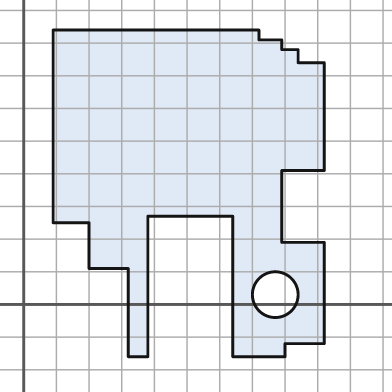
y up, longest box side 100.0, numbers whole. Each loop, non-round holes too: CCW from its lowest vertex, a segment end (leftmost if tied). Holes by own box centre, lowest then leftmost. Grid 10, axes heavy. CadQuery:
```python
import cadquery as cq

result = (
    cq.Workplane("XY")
    .moveTo(32.0, -16.0)
    .lineTo(38.0, -16.0)
    .lineTo(38.0, 27.0)
    .lineTo(64.0, 27.0)
    .lineTo(64.0, -16.0)
    .lineTo(80.0, -16.0)
    .lineTo(80.0, -12.0)
    .lineTo(92.0, -12.0)
    .lineTo(92.0, 19.0)
    .lineTo(79.0, 19.0)
    .lineTo(79.0, 41.0)
    .lineTo(92.0, 41.0)
    .lineTo(92.0, 74.0)
    .lineTo(84.0, 74.0)
    .lineTo(84.0, 78.0)
    .lineTo(79.0, 78.0)
    .lineTo(79.0, 81.0)
    .lineTo(72.0, 81.0)
    .lineTo(72.0, 84.0)
    .lineTo(9.0, 84.0)
    .lineTo(9.0, 25.0)
    .lineTo(20.0, 25.0)
    .lineTo(20.0, 11.0)
    .lineTo(32.0, 11.0)
    .close()
    .moveTo(77.0, 3.0)
    .circle(7.0)
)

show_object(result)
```